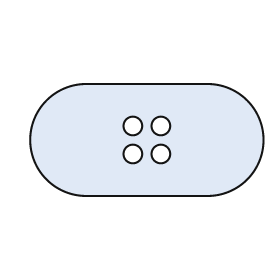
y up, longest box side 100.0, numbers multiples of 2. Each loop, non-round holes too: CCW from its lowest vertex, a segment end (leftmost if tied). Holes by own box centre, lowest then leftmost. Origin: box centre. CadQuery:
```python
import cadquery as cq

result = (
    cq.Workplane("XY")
    .moveTo(-26.0, -24.0)
    .lineTo(26.0, -24.0)
    .threePointArc((50.0, 0.0), (26.0, 24.0))
    .lineTo(-26.0, 24.0)
    .threePointArc((-50.0, 0.0), (-26.0, -24.0))
    .close()
    .moveTo(-6.0, -6.0)
    .circle(4.0)
    .moveTo(6.0, -6.0)
    .circle(4.0)
    .moveTo(-6.0, 6.0)
    .circle(4.0)
    .moveTo(6.0, 6.0)
    .circle(4.0)
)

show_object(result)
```